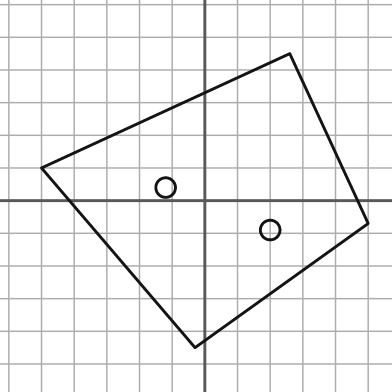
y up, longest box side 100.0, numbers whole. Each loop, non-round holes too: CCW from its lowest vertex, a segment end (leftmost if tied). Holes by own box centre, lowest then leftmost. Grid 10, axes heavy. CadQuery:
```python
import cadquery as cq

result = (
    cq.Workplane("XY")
    .moveTo(-3.0, -45.0)
    .lineTo(50.0, -7.0)
    .lineTo(26.0, 45.0)
    .lineTo(-50.0, 10.0)
    .close()
    .moveTo(20.0, -9.0)
    .circle(3.0)
    .moveTo(-12.0, 4.0)
    .circle(3.0)
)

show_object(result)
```